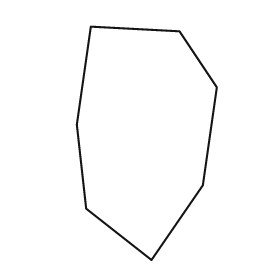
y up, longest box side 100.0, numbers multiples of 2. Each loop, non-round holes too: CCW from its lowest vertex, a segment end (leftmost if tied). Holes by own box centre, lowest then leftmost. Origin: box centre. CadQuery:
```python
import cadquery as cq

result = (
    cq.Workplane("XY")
    .moveTo(2.0, -50.0)
    .lineTo(24.0, -18.0)
    .lineTo(30.0, 24.0)
    .lineTo(14.0, 48.0)
    .lineTo(-24.0, 50.0)
    .lineTo(-30.0, 8.0)
    .lineTo(-26.0, -28.0)
    .close()
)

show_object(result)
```